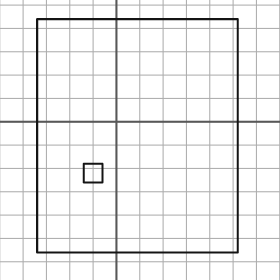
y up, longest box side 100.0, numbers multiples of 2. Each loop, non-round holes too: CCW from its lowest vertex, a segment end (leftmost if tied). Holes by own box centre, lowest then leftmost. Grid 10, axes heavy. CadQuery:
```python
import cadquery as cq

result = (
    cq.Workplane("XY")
    .moveTo(-34.0, -56.0)
    .lineTo(52.0, -56.0)
    .lineTo(52.0, 44.0)
    .lineTo(-34.0, 44.0)
    .close()
    .moveTo(-14.0, -26.0)
    .lineTo(-6.0, -26.0)
    .lineTo(-6.0, -18.0)
    .lineTo(-14.0, -18.0)
    .close()
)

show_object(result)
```